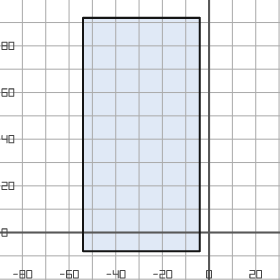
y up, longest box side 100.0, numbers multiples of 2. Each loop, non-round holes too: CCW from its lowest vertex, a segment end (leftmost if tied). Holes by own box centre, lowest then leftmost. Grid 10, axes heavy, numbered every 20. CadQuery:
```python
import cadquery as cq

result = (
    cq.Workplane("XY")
    .moveTo(-54.0, -8.0)
    .lineTo(-4.0, -8.0)
    .lineTo(-4.0, 92.0)
    .lineTo(-54.0, 92.0)
    .close()
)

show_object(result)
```